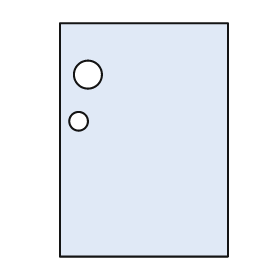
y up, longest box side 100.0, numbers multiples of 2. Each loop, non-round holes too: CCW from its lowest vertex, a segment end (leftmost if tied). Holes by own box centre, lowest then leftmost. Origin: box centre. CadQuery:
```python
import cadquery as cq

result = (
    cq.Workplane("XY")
    .moveTo(-36.0, -50.0)
    .lineTo(36.0, -50.0)
    .lineTo(36.0, 50.0)
    .lineTo(-36.0, 50.0)
    .close()
    .moveTo(-28.0, 8.0)
    .circle(4.0)
    .moveTo(-24.0, 28.0)
    .circle(6.0)
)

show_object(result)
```